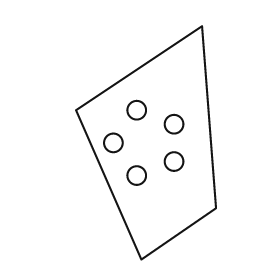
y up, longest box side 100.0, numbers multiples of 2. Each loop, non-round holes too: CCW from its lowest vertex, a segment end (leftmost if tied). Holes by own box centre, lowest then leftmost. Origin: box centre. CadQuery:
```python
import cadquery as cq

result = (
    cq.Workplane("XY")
    .moveTo(-2.0, -50.0)
    .lineTo(30.0, -28.0)
    .lineTo(24.0, 50.0)
    .lineTo(-30.0, 14.0)
    .close()
    .moveTo(-4.0, -14.0)
    .circle(4.0)
    .moveTo(12.0, -8.0)
    .circle(4.0)
    .moveTo(-14.0, 0.0)
    .circle(4.0)
    .moveTo(12.0, 8.0)
    .circle(4.0)
    .moveTo(-4.0, 14.0)
    .circle(4.0)
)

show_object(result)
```